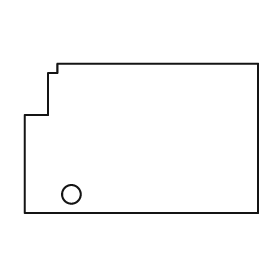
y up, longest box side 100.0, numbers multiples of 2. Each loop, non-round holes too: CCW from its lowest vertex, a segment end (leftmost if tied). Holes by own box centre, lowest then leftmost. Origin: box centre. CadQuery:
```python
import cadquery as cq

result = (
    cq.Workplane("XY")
    .moveTo(-50.0, -32.0)
    .lineTo(50.0, -32.0)
    .lineTo(50.0, 32.0)
    .lineTo(-36.0, 32.0)
    .lineTo(-36.0, 28.0)
    .lineTo(-40.0, 28.0)
    .lineTo(-40.0, 10.0)
    .lineTo(-50.0, 10.0)
    .close()
    .moveTo(-30.0, -24.0)
    .circle(4.0)
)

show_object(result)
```